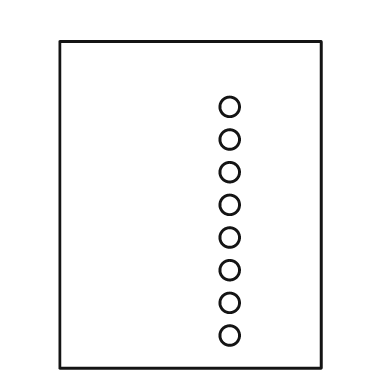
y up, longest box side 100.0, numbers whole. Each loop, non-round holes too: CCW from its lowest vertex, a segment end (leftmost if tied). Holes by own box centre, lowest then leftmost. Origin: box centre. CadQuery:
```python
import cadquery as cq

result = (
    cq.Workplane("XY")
    .moveTo(-40.0, -50.0)
    .lineTo(40.0, -50.0)
    .lineTo(40.0, 50.0)
    .lineTo(-40.0, 50.0)
    .close()
    .moveTo(12.0, -40.0)
    .circle(3.0)
    .moveTo(12.0, -30.0)
    .circle(3.0)
    .moveTo(12.0, -20.0)
    .circle(3.0)
    .moveTo(12.0, -10.0)
    .circle(3.0)
    .moveTo(12.0, 0.0)
    .circle(3.0)
    .moveTo(12.0, 10.0)
    .circle(3.0)
    .moveTo(12.0, 20.0)
    .circle(3.0)
    .moveTo(12.0, 30.0)
    .circle(3.0)
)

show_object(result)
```